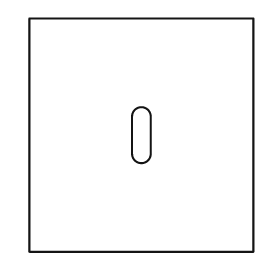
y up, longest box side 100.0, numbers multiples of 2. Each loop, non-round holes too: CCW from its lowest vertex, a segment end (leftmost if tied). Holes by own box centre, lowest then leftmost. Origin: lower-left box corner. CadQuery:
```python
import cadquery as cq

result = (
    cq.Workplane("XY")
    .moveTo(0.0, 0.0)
    .lineTo(96.0, 0.0)
    .lineTo(96.0, 100.0)
    .lineTo(0.0, 100.0)
    .close()
    .moveTo(44.0, 42.0)
    .threePointArc((48.0, 38.0), (52.0, 42.0))
    .lineTo(52.0, 58.0)
    .threePointArc((48.0, 62.0), (44.0, 58.0))
    .close()
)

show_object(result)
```